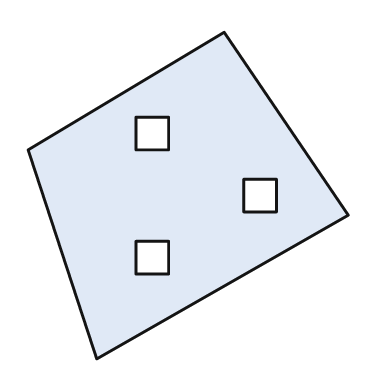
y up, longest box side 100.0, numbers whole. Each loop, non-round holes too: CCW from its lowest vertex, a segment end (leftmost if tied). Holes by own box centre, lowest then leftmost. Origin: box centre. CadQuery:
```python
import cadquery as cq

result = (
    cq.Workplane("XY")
    .moveTo(-28.0, -50.0)
    .lineTo(49.0, -6.0)
    .lineTo(11.0, 50.0)
    .lineTo(-49.0, 14.0)
    .close()
    .moveTo(-16.0, -24.0)
    .lineTo(-6.0, -24.0)
    .lineTo(-6.0, -14.0)
    .lineTo(-16.0, -14.0)
    .close()
    .moveTo(17.0, -5.0)
    .lineTo(27.0, -5.0)
    .lineTo(27.0, 5.0)
    .lineTo(17.0, 5.0)
    .close()
    .moveTo(-16.0, 14.0)
    .lineTo(-6.0, 14.0)
    .lineTo(-6.0, 24.0)
    .lineTo(-16.0, 24.0)
    .close()
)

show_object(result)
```